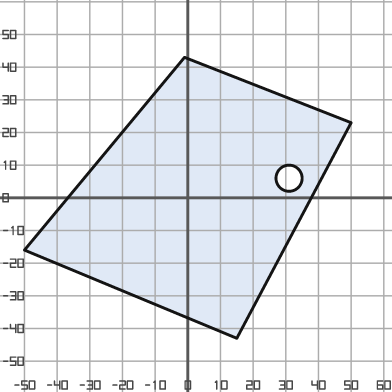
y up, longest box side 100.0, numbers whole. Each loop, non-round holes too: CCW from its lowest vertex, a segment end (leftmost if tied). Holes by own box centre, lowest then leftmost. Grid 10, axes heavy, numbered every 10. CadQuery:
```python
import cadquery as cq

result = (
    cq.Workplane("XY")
    .moveTo(15.0, -43.0)
    .lineTo(50.0, 23.0)
    .lineTo(-1.0, 43.0)
    .lineTo(-50.0, -16.0)
    .close()
    .moveTo(31.0, 6.0)
    .circle(4.0)
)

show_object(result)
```